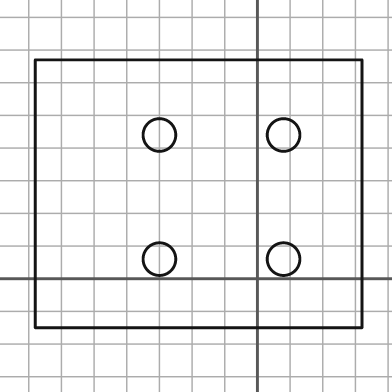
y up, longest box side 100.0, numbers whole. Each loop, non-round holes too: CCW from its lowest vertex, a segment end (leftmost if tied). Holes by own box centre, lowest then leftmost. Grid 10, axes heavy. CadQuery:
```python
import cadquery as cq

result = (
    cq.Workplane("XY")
    .moveTo(-68.0, -15.0)
    .lineTo(32.0, -15.0)
    .lineTo(32.0, 67.0)
    .lineTo(-68.0, 67.0)
    .close()
    .moveTo(-30.0, 6.0)
    .circle(5.0)
    .moveTo(8.0, 6.0)
    .circle(5.0)
    .moveTo(-30.0, 44.0)
    .circle(5.0)
    .moveTo(8.0, 44.0)
    .circle(5.0)
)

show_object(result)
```